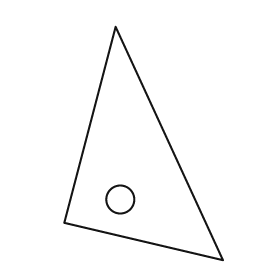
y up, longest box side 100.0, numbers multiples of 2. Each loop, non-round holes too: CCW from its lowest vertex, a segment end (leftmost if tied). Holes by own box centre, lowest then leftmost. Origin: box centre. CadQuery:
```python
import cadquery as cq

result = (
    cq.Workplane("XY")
    .moveTo(34.0, -50.0)
    .lineTo(-12.0, 50.0)
    .lineTo(-34.0, -34.0)
    .close()
    .moveTo(-10.0, -24.0)
    .circle(6.0)
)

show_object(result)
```